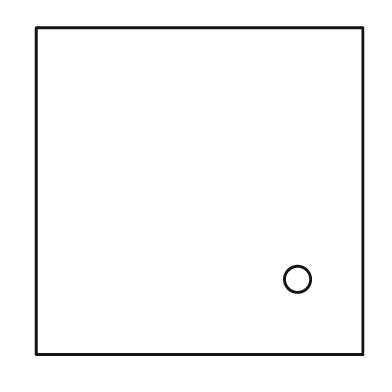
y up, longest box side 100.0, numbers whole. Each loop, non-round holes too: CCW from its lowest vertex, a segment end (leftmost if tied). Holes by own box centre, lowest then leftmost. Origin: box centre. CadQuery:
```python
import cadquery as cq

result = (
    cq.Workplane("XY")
    .moveTo(-50.0, -50.0)
    .lineTo(50.0, -50.0)
    .lineTo(50.0, 50.0)
    .lineTo(-50.0, 50.0)
    .close()
    .moveTo(30.0, -27.0)
    .circle(4.0)
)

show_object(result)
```